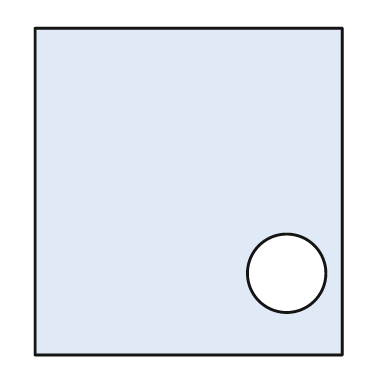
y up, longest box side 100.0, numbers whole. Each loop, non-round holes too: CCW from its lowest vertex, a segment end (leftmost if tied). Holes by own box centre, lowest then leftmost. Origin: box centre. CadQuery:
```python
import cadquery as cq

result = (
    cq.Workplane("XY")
    .moveTo(-47.0, -50.0)
    .lineTo(47.0, -50.0)
    .lineTo(47.0, 50.0)
    .lineTo(-47.0, 50.0)
    .close()
    .moveTo(30.0, -25.0)
    .circle(12.0)
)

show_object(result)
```